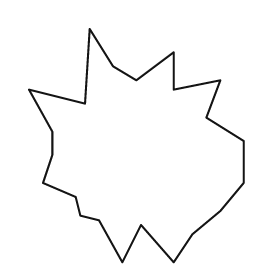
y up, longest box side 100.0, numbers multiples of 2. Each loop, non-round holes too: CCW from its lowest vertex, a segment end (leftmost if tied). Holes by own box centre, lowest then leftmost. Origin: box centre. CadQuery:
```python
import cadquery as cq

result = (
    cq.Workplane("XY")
    .moveTo(-6.0, -50.0)
    .lineTo(2.0, -34.0)
    .lineTo(16.0, -50.0)
    .lineTo(24.0, -38.0)
    .lineTo(36.0, -28.0)
    .lineTo(46.0, -16.0)
    .lineTo(46.0, 2.0)
    .lineTo(30.0, 12.0)
    .lineTo(36.0, 28.0)
    .lineTo(16.0, 24.0)
    .lineTo(16.0, 40.0)
    .lineTo(0.0, 28.0)
    .lineTo(-10.0, 34.0)
    .lineTo(-20.0, 50.0)
    .lineTo(-22.0, 18.0)
    .lineTo(-46.0, 24.0)
    .lineTo(-36.0, 6.0)
    .lineTo(-36.0, -4.0)
    .lineTo(-40.0, -16.0)
    .lineTo(-26.0, -22.0)
    .lineTo(-24.0, -30.0)
    .lineTo(-16.0, -32.0)
    .close()
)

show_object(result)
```